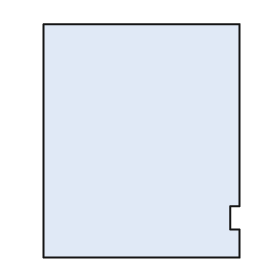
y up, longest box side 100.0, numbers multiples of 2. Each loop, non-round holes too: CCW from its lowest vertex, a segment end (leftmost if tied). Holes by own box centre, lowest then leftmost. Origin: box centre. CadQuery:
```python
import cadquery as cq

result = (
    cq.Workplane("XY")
    .moveTo(-42.0, -50.0)
    .lineTo(42.0, -50.0)
    .lineTo(42.0, -38.0)
    .lineTo(38.0, -38.0)
    .lineTo(38.0, -28.0)
    .lineTo(42.0, -28.0)
    .lineTo(42.0, 50.0)
    .lineTo(-42.0, 50.0)
    .close()
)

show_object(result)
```